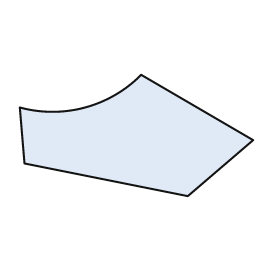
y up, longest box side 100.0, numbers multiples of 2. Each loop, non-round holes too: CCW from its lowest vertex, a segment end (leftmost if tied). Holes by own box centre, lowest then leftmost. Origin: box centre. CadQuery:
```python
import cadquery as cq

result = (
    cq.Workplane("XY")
    .moveTo(22.0, -26.0)
    .lineTo(50.0, -2.0)
    .lineTo(2.0, 26.0)
    .threePointArc((-22.0, 12.0), (-50.0, 12.0))
    .lineTo(-48.0, -12.0)
    .close()
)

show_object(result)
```